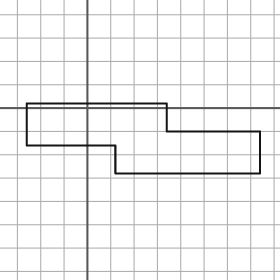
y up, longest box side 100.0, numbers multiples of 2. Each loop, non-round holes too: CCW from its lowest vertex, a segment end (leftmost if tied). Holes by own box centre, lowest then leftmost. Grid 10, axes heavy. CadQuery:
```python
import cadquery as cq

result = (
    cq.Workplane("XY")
    .moveTo(12.0, -28.0)
    .lineTo(74.0, -28.0)
    .lineTo(74.0, -10.0)
    .lineTo(34.0, -10.0)
    .lineTo(34.0, 2.0)
    .lineTo(-26.0, 2.0)
    .lineTo(-26.0, -16.0)
    .lineTo(12.0, -16.0)
    .close()
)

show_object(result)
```